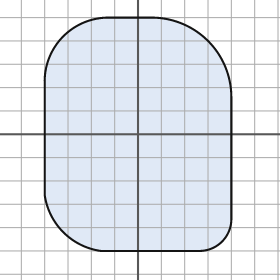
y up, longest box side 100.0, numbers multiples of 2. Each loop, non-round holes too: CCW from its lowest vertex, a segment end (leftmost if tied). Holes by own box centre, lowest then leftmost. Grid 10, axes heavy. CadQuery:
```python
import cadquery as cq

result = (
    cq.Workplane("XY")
    .moveTo(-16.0, -50.0)
    .lineTo(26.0, -50.0)
    .threePointArc((36.0, -46.0), (40.0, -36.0))
    .lineTo(40.0, 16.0)
    .threePointArc((30.0, 40.0), (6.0, 50.0))
    .lineTo(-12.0, 50.0)
    .threePointArc((-32.0, 42.0), (-40.0, 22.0))
    .lineTo(-40.0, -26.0)
    .threePointArc((-32.0, -42.0), (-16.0, -50.0))
    .close()
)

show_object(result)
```